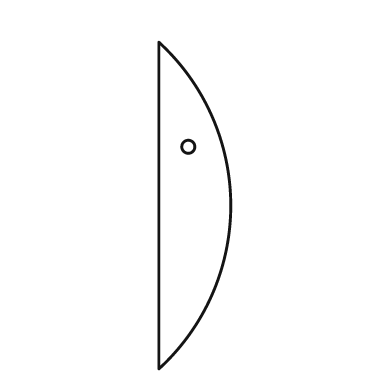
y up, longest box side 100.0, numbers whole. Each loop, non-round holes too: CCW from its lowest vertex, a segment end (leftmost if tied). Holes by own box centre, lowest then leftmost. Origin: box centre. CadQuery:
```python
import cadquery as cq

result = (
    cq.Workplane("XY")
    .moveTo(-11.0, -50.0)
    .threePointArc((11.0, 0.0), (-11.0, 50.0))
    .close()
    .moveTo(-2.0, 18.0)
    .circle(2.0)
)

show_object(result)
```